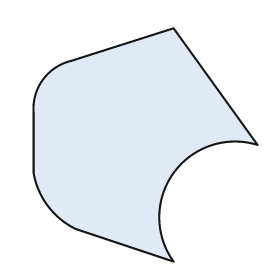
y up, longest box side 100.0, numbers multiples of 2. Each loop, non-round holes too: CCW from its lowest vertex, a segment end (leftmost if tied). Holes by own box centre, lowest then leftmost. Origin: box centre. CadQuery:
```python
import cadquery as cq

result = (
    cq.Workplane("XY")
    .moveTo(12.0, -50.0)
    .threePointArc((12.0, -12.0), (48.0, 0.0))
    .lineTo(12.0, 50.0)
    .lineTo(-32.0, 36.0)
    .threePointArc((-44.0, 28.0), (-48.0, 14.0))
    .lineTo(-48.0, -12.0)
    .threePointArc((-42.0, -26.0), (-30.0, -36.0))
    .close()
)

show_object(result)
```